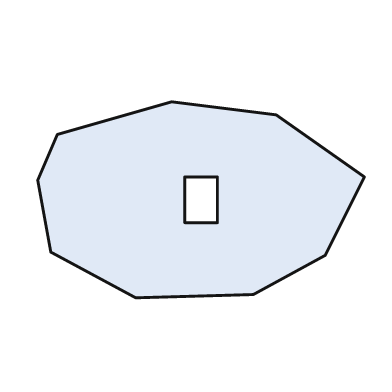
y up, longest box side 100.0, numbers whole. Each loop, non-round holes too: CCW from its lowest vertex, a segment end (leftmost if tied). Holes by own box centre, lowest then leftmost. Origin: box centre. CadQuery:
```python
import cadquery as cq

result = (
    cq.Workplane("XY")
    .moveTo(-20.0, -30.0)
    .lineTo(16.0, -29.0)
    .lineTo(38.0, -17.0)
    .lineTo(50.0, 7.0)
    .lineTo(23.0, 26.0)
    .lineTo(-9.0, 30.0)
    .lineTo(-44.0, 20.0)
    .lineTo(-50.0, 6.0)
    .lineTo(-46.0, -16.0)
    .close()
    .moveTo(-5.0, -7.0)
    .lineTo(5.0, -7.0)
    .lineTo(5.0, 7.0)
    .lineTo(-5.0, 7.0)
    .close()
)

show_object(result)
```